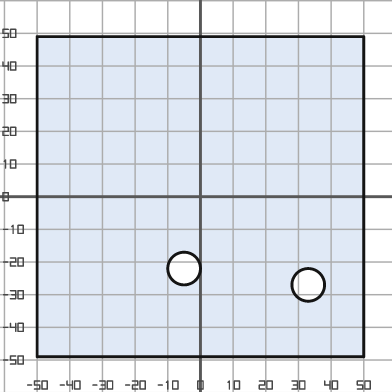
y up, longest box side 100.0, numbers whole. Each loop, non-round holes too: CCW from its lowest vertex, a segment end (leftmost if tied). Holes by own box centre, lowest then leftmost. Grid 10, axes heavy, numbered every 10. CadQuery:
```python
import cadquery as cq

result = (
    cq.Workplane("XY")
    .moveTo(-50.0, -49.0)
    .lineTo(50.0, -49.0)
    .lineTo(50.0, 49.0)
    .lineTo(-50.0, 49.0)
    .close()
    .moveTo(33.0, -27.0)
    .circle(5.0)
    .moveTo(-5.0, -22.0)
    .circle(5.0)
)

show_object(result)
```